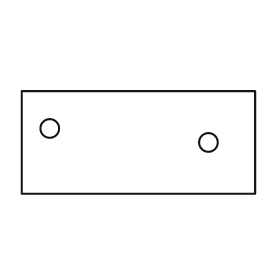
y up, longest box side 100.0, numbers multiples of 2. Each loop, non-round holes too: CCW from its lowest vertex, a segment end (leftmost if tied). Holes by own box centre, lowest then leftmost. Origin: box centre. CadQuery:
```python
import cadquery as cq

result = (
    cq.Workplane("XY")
    .moveTo(-50.0, -22.0)
    .lineTo(50.0, -22.0)
    .lineTo(50.0, 22.0)
    .lineTo(-50.0, 22.0)
    .close()
    .moveTo(30.0, 0.0)
    .circle(4.0)
    .moveTo(-38.0, 6.0)
    .circle(4.0)
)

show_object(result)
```